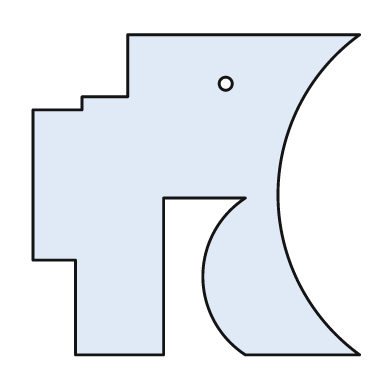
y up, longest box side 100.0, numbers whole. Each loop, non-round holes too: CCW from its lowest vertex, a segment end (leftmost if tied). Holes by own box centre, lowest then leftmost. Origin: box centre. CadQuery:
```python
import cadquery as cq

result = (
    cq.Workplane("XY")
    .moveTo(-37.0, -49.0)
    .lineTo(-10.0, -49.0)
    .lineTo(-10.0, -1.0)
    .lineTo(15.0, -1.0)
    .threePointArc((2.0, -25.0), (15.0, -49.0))
    .lineTo(50.0, -49.0)
    .threePointArc((25.0, 0.0), (50.0, 49.0))
    .lineTo(-21.0, 49.0)
    .lineTo(-21.0, 30.0)
    .lineTo(-35.0, 30.0)
    .lineTo(-35.0, 26.0)
    .lineTo(-50.0, 26.0)
    .lineTo(-50.0, -20.0)
    .lineTo(-37.0, -20.0)
    .close()
    .moveTo(9.0, 34.0)
    .circle(2.0)
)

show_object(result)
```